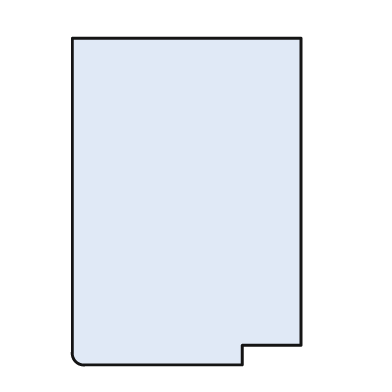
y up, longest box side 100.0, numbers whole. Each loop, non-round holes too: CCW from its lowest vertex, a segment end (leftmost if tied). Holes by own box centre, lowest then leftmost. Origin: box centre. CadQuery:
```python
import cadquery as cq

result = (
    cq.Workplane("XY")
    .moveTo(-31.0, -50.0)
    .lineTo(17.0, -50.0)
    .lineTo(17.0, -44.0)
    .lineTo(35.0, -44.0)
    .lineTo(35.0, 50.0)
    .lineTo(-35.0, 50.0)
    .lineTo(-35.0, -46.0)
    .threePointArc((-34.0, -49.0), (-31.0, -50.0))
    .close()
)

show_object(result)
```